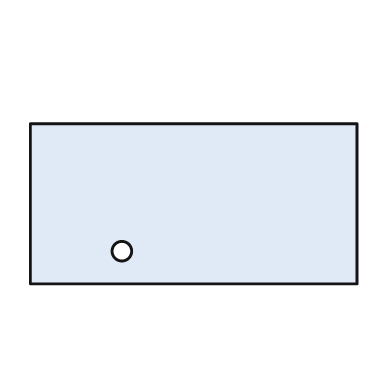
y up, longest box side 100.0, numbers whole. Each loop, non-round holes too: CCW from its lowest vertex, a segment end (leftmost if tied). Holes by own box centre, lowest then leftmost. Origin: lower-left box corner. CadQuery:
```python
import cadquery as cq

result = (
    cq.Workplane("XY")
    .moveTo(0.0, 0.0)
    .lineTo(100.0, 0.0)
    .lineTo(100.0, 49.0)
    .lineTo(0.0, 49.0)
    .close()
    .moveTo(28.0, 10.0)
    .circle(3.0)
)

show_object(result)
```